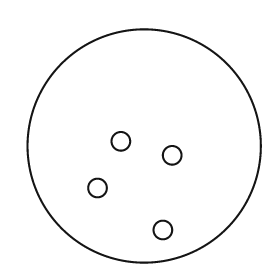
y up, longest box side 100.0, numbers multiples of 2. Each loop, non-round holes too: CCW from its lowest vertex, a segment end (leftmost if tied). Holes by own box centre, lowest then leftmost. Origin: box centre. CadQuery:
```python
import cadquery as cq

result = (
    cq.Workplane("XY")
    .moveTo(0.0, 0.0)
    .circle(50.0)
    .moveTo(8.0, -36.0)
    .circle(4.0)
    .moveTo(-20.0, -18.0)
    .circle(4.0)
    .moveTo(12.0, -4.0)
    .circle(4.0)
    .moveTo(-10.0, 2.0)
    .circle(4.0)
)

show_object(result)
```